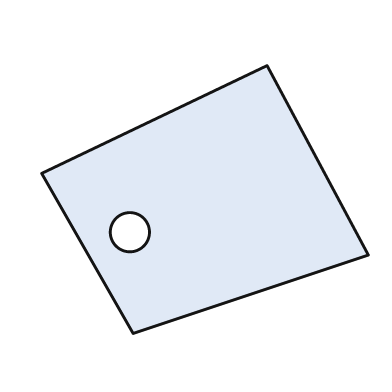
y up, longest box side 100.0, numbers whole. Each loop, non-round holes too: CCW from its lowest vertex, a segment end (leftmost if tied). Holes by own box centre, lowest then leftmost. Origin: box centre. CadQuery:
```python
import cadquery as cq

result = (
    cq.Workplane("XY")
    .moveTo(-22.0, -41.0)
    .lineTo(50.0, -17.0)
    .lineTo(19.0, 41.0)
    .lineTo(-50.0, 8.0)
    .close()
    .moveTo(-23.0, -10.0)
    .circle(6.0)
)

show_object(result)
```